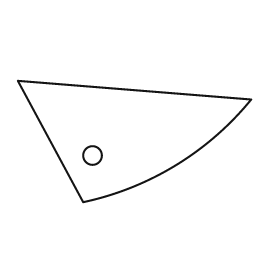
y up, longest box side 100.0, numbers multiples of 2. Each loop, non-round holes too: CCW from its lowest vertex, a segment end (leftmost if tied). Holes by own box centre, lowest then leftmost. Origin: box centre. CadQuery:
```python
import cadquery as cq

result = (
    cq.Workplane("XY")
    .moveTo(-22.0, -26.0)
    .threePointArc((18.0, -10.0), (50.0, 18.0))
    .lineTo(-50.0, 26.0)
    .close()
    .moveTo(-18.0, -6.0)
    .circle(4.0)
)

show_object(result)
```